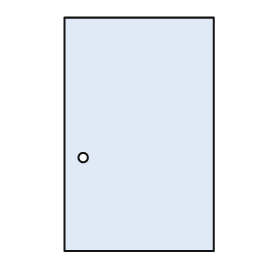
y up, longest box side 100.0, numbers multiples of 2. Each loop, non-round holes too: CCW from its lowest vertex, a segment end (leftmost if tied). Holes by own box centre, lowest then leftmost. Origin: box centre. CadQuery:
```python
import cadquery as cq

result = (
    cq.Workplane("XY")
    .moveTo(-32.0, -50.0)
    .lineTo(32.0, -50.0)
    .lineTo(32.0, 50.0)
    .lineTo(-32.0, 50.0)
    .close()
    .moveTo(-24.0, -10.0)
    .circle(2.0)
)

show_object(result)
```